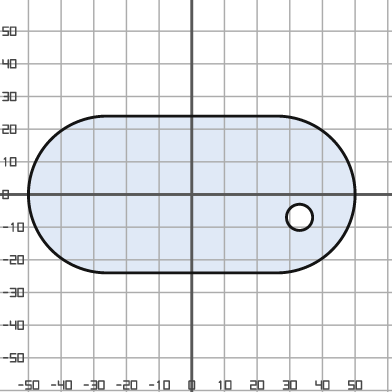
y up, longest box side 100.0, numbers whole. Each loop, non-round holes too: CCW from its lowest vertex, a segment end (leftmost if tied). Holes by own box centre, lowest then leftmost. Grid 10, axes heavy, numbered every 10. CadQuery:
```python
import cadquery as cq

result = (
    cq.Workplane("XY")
    .moveTo(-26.0, -24.0)
    .lineTo(26.0, -24.0)
    .threePointArc((50.0, 0.0), (26.0, 24.0))
    .lineTo(-26.0, 24.0)
    .threePointArc((-50.0, 0.0), (-26.0, -24.0))
    .close()
    .moveTo(33.0, -7.0)
    .circle(4.0)
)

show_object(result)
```